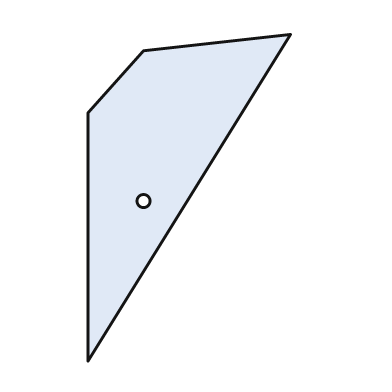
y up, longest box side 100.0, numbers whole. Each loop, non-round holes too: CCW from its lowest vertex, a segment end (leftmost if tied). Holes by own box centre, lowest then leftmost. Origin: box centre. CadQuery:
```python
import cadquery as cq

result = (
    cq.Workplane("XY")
    .moveTo(-31.0, -50.0)
    .lineTo(31.0, 50.0)
    .lineTo(-14.0, 45.0)
    .lineTo(-31.0, 26.0)
    .close()
    .moveTo(-14.0, -1.0)
    .circle(2.0)
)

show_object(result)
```